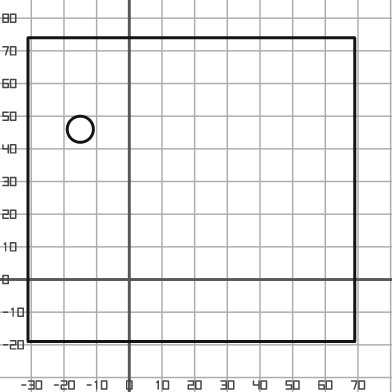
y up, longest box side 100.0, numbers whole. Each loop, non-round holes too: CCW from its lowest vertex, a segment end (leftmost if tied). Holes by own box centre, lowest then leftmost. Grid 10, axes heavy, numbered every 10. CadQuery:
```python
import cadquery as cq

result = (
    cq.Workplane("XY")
    .moveTo(-31.0, -19.0)
    .lineTo(69.0, -19.0)
    .lineTo(69.0, 74.0)
    .lineTo(-31.0, 74.0)
    .close()
    .moveTo(-15.0, 46.0)
    .circle(4.0)
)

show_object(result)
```